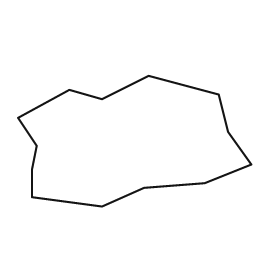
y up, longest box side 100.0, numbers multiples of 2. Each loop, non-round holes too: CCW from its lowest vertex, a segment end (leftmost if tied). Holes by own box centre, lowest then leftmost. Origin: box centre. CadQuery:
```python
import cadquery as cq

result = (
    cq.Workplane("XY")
    .moveTo(-14.0, -28.0)
    .lineTo(4.0, -20.0)
    .lineTo(30.0, -18.0)
    .lineTo(50.0, -10.0)
    .lineTo(40.0, 4.0)
    .lineTo(36.0, 20.0)
    .lineTo(6.0, 28.0)
    .lineTo(-14.0, 18.0)
    .lineTo(-28.0, 22.0)
    .lineTo(-50.0, 10.0)
    .lineTo(-42.0, -2.0)
    .lineTo(-44.0, -12.0)
    .lineTo(-44.0, -24.0)
    .close()
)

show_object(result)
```